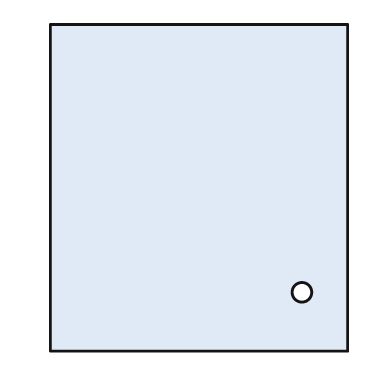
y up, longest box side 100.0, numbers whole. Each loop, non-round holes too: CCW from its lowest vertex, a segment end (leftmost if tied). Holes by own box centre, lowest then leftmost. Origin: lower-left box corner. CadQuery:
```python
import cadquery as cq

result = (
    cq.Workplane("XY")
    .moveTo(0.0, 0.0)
    .lineTo(91.0, 0.0)
    .lineTo(91.0, 100.0)
    .lineTo(0.0, 100.0)
    .close()
    .moveTo(77.0, 18.0)
    .circle(3.0)
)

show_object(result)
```